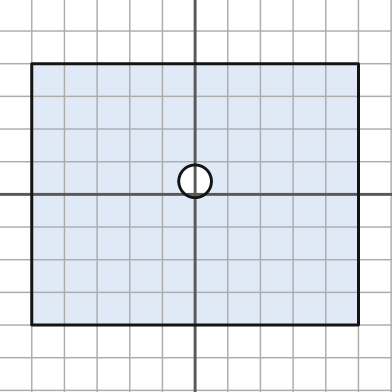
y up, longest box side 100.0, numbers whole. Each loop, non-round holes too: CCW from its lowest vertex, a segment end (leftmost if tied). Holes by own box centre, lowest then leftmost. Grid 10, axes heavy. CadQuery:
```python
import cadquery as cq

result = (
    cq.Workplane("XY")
    .moveTo(-50.0, -40.0)
    .lineTo(50.0, -40.0)
    .lineTo(50.0, 40.0)
    .lineTo(-50.0, 40.0)
    .close()
    .moveTo(0.0, 4.0)
    .circle(5.0)
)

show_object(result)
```